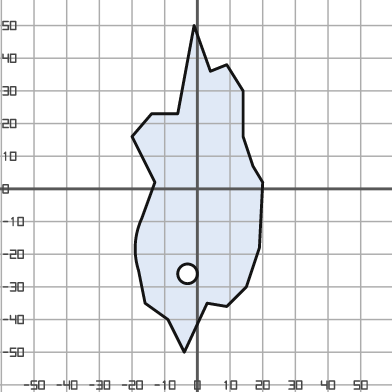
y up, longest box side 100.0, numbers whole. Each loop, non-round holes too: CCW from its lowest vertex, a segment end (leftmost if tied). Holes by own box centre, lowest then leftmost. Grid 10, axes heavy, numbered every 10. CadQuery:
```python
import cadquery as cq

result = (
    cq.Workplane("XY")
    .moveTo(-4.0, -50.0)
    .lineTo(3.0, -35.0)
    .lineTo(9.0, -36.0)
    .lineTo(15.0, -30.0)
    .lineTo(19.0, -18.0)
    .lineTo(20.0, 2.0)
    .lineTo(17.0, 7.0)
    .lineTo(14.0, 16.0)
    .lineTo(14.0, 30.0)
    .lineTo(9.0, 38.0)
    .lineTo(4.0, 36.0)
    .lineTo(-1.0, 50.0)
    .lineTo(-6.0, 23.0)
    .lineTo(-14.0, 23.0)
    .lineTo(-20.0, 16.0)
    .lineTo(-13.0, 2.0)
    .lineTo(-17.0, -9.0)
    .threePointArc((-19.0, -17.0), (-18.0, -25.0))
    .lineTo(-16.0, -35.0)
    .lineTo(-9.0, -40.0)
    .close()
    .moveTo(-3.0, -26.0)
    .circle(3.0)
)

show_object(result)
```